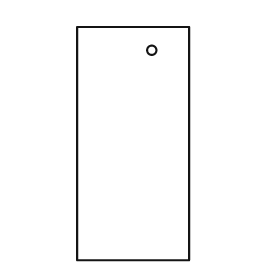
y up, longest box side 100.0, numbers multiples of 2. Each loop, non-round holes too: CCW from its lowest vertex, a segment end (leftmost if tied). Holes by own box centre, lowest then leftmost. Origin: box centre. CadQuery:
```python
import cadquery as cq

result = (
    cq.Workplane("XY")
    .moveTo(-24.0, -50.0)
    .lineTo(24.0, -50.0)
    .lineTo(24.0, 50.0)
    .lineTo(-24.0, 50.0)
    .close()
    .moveTo(8.0, 40.0)
    .circle(2.0)
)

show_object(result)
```